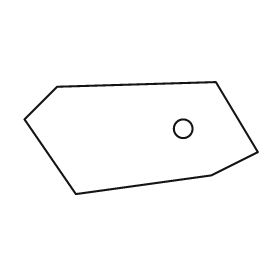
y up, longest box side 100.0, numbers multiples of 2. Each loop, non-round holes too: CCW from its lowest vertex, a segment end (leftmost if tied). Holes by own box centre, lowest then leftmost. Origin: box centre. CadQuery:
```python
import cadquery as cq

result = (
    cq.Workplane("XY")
    .moveTo(-28.0, -24.0)
    .lineTo(30.0, -16.0)
    .lineTo(50.0, -6.0)
    .lineTo(32.0, 24.0)
    .lineTo(-36.0, 22.0)
    .lineTo(-50.0, 8.0)
    .close()
    .moveTo(18.0, 4.0)
    .circle(4.0)
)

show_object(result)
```